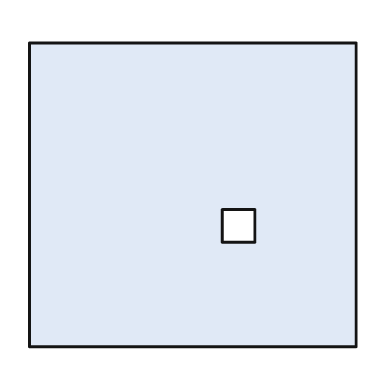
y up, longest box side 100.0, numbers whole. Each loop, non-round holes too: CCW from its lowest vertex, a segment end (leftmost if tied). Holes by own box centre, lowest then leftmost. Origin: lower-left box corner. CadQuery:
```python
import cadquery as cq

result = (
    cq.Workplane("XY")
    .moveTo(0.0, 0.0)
    .lineTo(100.0, 0.0)
    .lineTo(100.0, 93.0)
    .lineTo(0.0, 93.0)
    .close()
    .moveTo(59.0, 32.0)
    .lineTo(69.0, 32.0)
    .lineTo(69.0, 42.0)
    .lineTo(59.0, 42.0)
    .close()
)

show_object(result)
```